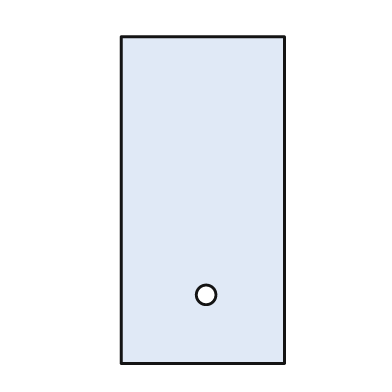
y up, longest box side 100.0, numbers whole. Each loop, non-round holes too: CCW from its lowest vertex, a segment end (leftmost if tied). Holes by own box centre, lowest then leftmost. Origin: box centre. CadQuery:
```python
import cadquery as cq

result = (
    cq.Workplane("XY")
    .moveTo(-25.0, -50.0)
    .lineTo(25.0, -50.0)
    .lineTo(25.0, 50.0)
    .lineTo(-25.0, 50.0)
    .close()
    .moveTo(1.0, -29.0)
    .circle(3.0)
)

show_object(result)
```